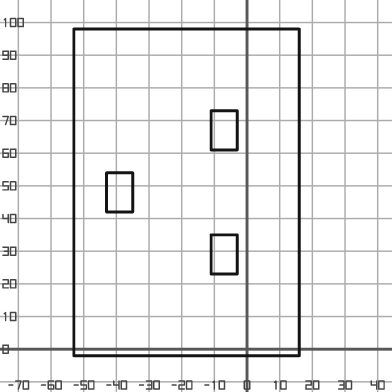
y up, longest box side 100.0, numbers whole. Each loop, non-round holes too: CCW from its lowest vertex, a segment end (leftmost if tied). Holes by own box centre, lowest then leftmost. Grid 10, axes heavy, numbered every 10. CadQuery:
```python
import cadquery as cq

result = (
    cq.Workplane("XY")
    .moveTo(-53.0, -2.0)
    .lineTo(16.0, -2.0)
    .lineTo(16.0, 98.0)
    .lineTo(-53.0, 98.0)
    .close()
    .moveTo(-11.0, 23.0)
    .lineTo(-3.0, 23.0)
    .lineTo(-3.0, 35.0)
    .lineTo(-11.0, 35.0)
    .close()
    .moveTo(-43.0, 42.0)
    .lineTo(-35.0, 42.0)
    .lineTo(-35.0, 54.0)
    .lineTo(-43.0, 54.0)
    .close()
    .moveTo(-11.0, 61.0)
    .lineTo(-3.0, 61.0)
    .lineTo(-3.0, 73.0)
    .lineTo(-11.0, 73.0)
    .close()
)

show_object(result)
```